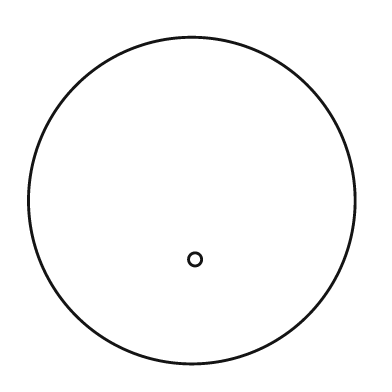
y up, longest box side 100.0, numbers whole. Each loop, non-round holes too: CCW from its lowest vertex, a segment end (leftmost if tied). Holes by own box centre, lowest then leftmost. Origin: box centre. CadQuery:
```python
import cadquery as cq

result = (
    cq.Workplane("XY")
    .moveTo(0.0, 0.0)
    .circle(50.0)
    .moveTo(1.0, -18.0)
    .circle(2.0)
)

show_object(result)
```